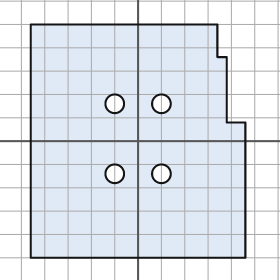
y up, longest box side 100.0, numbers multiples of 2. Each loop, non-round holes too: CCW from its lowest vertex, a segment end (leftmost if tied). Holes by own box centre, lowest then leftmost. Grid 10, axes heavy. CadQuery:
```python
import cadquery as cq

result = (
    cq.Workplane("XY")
    .moveTo(-46.0, -50.0)
    .lineTo(46.0, -50.0)
    .lineTo(46.0, 8.0)
    .lineTo(38.0, 8.0)
    .lineTo(38.0, 36.0)
    .lineTo(34.0, 36.0)
    .lineTo(34.0, 50.0)
    .lineTo(-46.0, 50.0)
    .close()
    .moveTo(-10.0, -14.0)
    .circle(4.0)
    .moveTo(10.0, -14.0)
    .circle(4.0)
    .moveTo(-10.0, 16.0)
    .circle(4.0)
    .moveTo(10.0, 16.0)
    .circle(4.0)
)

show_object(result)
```